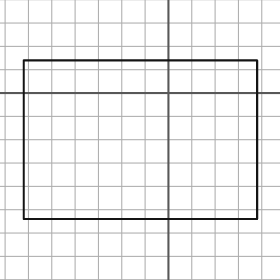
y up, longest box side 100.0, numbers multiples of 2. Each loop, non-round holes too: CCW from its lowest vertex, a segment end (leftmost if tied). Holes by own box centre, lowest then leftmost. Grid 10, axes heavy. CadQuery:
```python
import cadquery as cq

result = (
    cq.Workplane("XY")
    .moveTo(-62.0, -54.0)
    .lineTo(38.0, -54.0)
    .lineTo(38.0, 14.0)
    .lineTo(-62.0, 14.0)
    .close()
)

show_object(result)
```